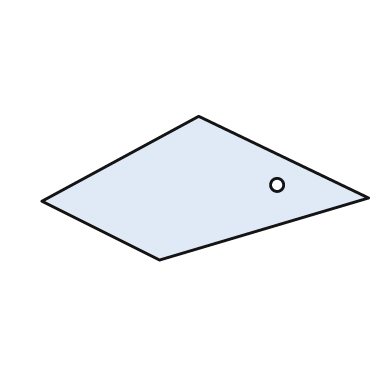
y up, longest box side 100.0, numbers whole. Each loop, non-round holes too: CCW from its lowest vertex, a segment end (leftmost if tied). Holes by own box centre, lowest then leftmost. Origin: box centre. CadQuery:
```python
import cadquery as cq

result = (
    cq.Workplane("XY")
    .moveTo(-14.0, -22.0)
    .lineTo(50.0, -3.0)
    .lineTo(-2.0, 22.0)
    .lineTo(-50.0, -4.0)
    .close()
    .moveTo(22.0, 1.0)
    .circle(2.0)
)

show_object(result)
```